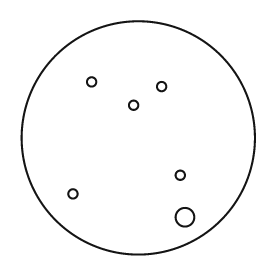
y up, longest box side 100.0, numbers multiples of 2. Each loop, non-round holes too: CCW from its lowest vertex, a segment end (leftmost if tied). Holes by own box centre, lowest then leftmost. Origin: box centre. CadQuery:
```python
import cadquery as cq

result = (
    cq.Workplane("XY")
    .moveTo(0.0, 0.0)
    .circle(50.0)
    .moveTo(20.0, -34.0)
    .circle(4.0)
    .moveTo(-28.0, -24.0)
    .circle(2.0)
    .moveTo(18.0, -16.0)
    .circle(2.0)
    .moveTo(-2.0, 14.0)
    .circle(2.0)
    .moveTo(10.0, 22.0)
    .circle(2.0)
    .moveTo(-20.0, 24.0)
    .circle(2.0)
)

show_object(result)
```